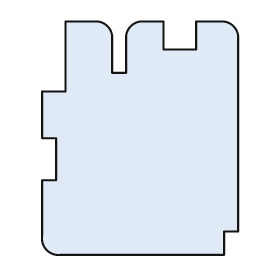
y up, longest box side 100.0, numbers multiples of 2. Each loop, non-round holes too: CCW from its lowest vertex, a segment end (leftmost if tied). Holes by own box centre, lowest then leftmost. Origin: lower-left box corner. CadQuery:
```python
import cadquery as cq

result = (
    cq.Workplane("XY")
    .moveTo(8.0, 0.0)
    .lineTo(78.0, 0.0)
    .lineTo(78.0, 10.0)
    .lineTo(84.0, 10.0)
    .lineTo(84.0, 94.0)
    .threePointArc((82.0, 98.0), (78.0, 100.0))
    .lineTo(66.0, 100.0)
    .lineTo(66.0, 88.0)
    .lineTo(52.0, 88.0)
    .lineTo(52.0, 100.0)
    .lineTo(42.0, 100.0)
    .threePointArc((38.0, 98.0), (36.0, 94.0))
    .lineTo(36.0, 78.0)
    .lineTo(30.0, 78.0)
    .lineTo(30.0, 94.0)
    .threePointArc((28.0, 98.0), (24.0, 100.0))
    .lineTo(10.0, 100.0)
    .lineTo(10.0, 70.0)
    .lineTo(0.0, 70.0)
    .lineTo(0.0, 50.0)
    .lineTo(6.0, 50.0)
    .lineTo(6.0, 32.0)
    .lineTo(0.0, 32.0)
    .lineTo(0.0, 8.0)
    .threePointArc((2.0, 2.0), (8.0, 0.0))
    .close()
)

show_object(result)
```